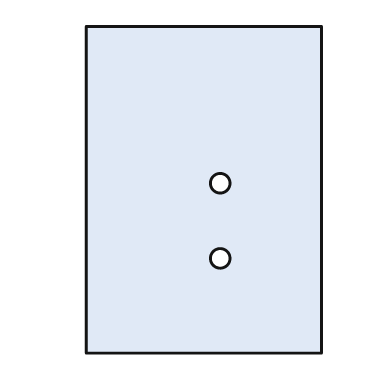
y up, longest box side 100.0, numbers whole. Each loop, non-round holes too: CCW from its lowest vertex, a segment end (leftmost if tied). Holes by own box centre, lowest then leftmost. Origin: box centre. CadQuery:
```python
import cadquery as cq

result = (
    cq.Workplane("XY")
    .moveTo(-36.0, -50.0)
    .lineTo(36.0, -50.0)
    .lineTo(36.0, 50.0)
    .lineTo(-36.0, 50.0)
    .close()
    .moveTo(5.0, -21.0)
    .circle(3.0)
    .moveTo(5.0, 2.0)
    .circle(3.0)
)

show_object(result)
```